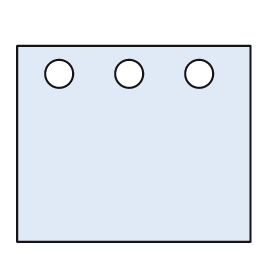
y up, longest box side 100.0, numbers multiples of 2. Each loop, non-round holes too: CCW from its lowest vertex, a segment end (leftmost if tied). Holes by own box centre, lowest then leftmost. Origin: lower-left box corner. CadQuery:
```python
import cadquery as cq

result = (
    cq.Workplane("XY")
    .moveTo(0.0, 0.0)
    .lineTo(100.0, 0.0)
    .lineTo(100.0, 84.0)
    .lineTo(0.0, 84.0)
    .close()
    .moveTo(18.0, 72.0)
    .circle(6.0)
    .moveTo(48.0, 72.0)
    .circle(6.0)
    .moveTo(78.0, 72.0)
    .circle(6.0)
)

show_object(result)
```